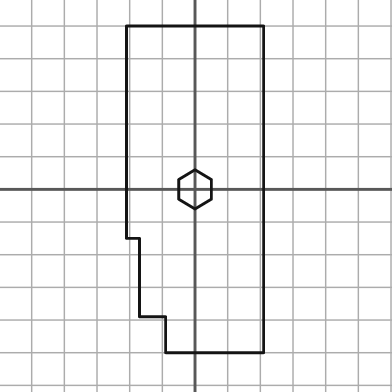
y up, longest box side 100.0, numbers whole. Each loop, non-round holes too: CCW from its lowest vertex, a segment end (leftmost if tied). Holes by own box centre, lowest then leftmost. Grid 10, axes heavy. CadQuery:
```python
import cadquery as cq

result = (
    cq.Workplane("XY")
    .moveTo(-9.0, -50.0)
    .lineTo(21.0, -50.0)
    .lineTo(21.0, 50.0)
    .lineTo(-21.0, 50.0)
    .lineTo(-21.0, -15.0)
    .lineTo(-17.0, -15.0)
    .lineTo(-17.0, -39.0)
    .lineTo(-9.0, -39.0)
    .close()
    .moveTo(0.0, -6.0)
    .lineTo(5.0, -3.0)
    .lineTo(5.0, 3.0)
    .lineTo(0.0, 6.0)
    .lineTo(-5.0, 3.0)
    .lineTo(-5.0, -3.0)
    .close()
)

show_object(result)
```